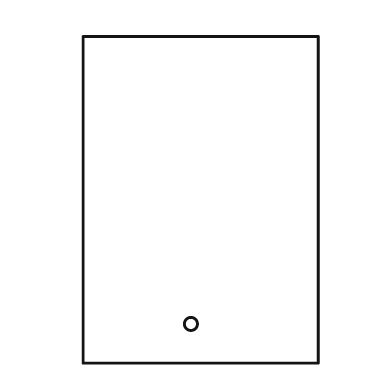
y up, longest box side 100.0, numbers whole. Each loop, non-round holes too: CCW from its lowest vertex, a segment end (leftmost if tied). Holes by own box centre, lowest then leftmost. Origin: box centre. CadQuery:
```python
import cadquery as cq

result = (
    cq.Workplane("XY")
    .moveTo(-36.0, -50.0)
    .lineTo(36.0, -50.0)
    .lineTo(36.0, 50.0)
    .lineTo(-36.0, 50.0)
    .close()
    .moveTo(-3.0, -38.0)
    .circle(2.0)
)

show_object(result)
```